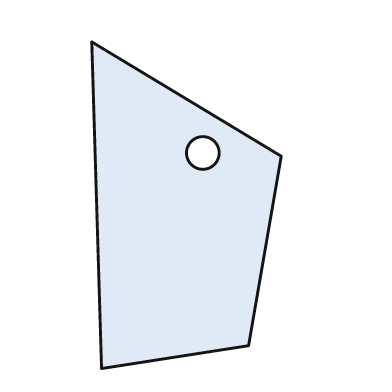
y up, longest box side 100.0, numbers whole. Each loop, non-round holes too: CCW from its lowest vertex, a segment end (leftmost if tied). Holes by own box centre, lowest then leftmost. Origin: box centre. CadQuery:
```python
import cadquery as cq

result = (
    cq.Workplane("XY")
    .moveTo(-26.0, -50.0)
    .lineTo(19.0, -43.0)
    .lineTo(29.0, 15.0)
    .lineTo(-29.0, 50.0)
    .close()
    .moveTo(5.0, 16.0)
    .circle(5.0)
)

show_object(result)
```